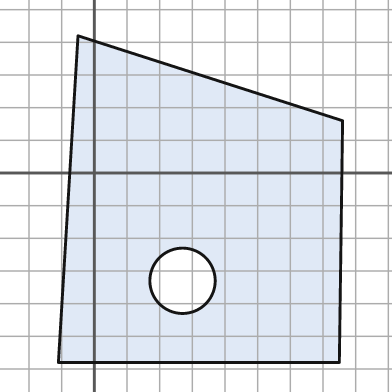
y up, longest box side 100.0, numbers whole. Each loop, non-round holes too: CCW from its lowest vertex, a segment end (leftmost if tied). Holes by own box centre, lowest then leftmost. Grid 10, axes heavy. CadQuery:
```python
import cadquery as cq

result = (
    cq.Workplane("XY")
    .moveTo(-11.0, -58.0)
    .lineTo(75.0, -58.0)
    .lineTo(76.0, 16.0)
    .lineTo(-5.0, 42.0)
    .close()
    .moveTo(27.0, -33.0)
    .circle(10.0)
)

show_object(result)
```